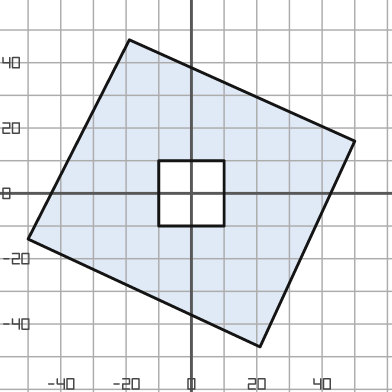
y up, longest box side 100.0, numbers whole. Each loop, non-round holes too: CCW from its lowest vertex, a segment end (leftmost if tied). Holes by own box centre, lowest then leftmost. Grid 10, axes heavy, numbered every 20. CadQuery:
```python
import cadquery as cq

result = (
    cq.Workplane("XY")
    .moveTo(21.0, -47.0)
    .lineTo(50.0, 16.0)
    .lineTo(-19.0, 47.0)
    .lineTo(-50.0, -14.0)
    .close()
    .moveTo(-10.0, -10.0)
    .lineTo(10.0, -10.0)
    .lineTo(10.0, 10.0)
    .lineTo(-10.0, 10.0)
    .close()
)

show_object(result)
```